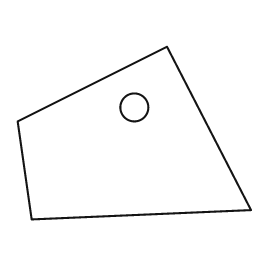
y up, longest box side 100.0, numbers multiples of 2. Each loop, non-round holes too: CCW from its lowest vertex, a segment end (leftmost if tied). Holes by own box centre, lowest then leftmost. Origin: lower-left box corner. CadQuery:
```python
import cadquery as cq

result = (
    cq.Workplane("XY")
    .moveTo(6.0, 0.0)
    .lineTo(100.0, 4.0)
    .lineTo(64.0, 74.0)
    .lineTo(0.0, 42.0)
    .close()
    .moveTo(50.0, 48.0)
    .circle(6.0)
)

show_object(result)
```